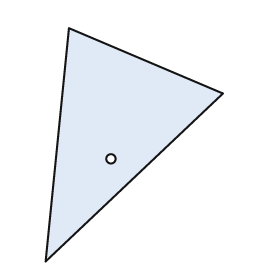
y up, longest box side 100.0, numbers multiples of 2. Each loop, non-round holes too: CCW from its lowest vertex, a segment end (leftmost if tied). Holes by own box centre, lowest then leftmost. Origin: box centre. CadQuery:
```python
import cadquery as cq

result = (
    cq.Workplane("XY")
    .moveTo(-38.0, -50.0)
    .lineTo(38.0, 22.0)
    .lineTo(-28.0, 50.0)
    .close()
    .moveTo(-10.0, -6.0)
    .circle(2.0)
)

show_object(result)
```